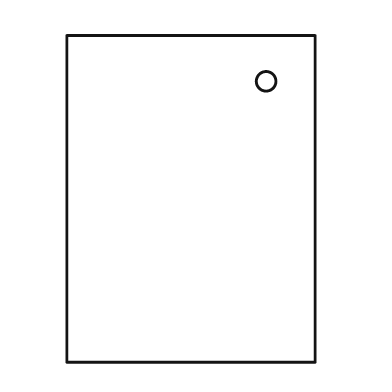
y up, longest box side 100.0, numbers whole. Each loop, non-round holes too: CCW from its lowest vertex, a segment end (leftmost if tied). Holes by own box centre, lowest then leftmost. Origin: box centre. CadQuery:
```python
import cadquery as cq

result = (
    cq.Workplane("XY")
    .moveTo(-38.0, -50.0)
    .lineTo(38.0, -50.0)
    .lineTo(38.0, 50.0)
    .lineTo(-38.0, 50.0)
    .close()
    .moveTo(23.0, 36.0)
    .circle(3.0)
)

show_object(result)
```